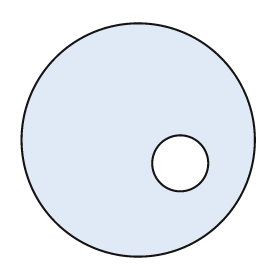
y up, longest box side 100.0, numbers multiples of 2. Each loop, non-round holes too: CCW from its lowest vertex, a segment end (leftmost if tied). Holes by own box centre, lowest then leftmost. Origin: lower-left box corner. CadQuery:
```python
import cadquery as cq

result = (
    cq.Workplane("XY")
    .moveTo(50.0, 50.0)
    .circle(50.0)
    .moveTo(68.0, 40.0)
    .circle(12.0)
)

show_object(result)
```